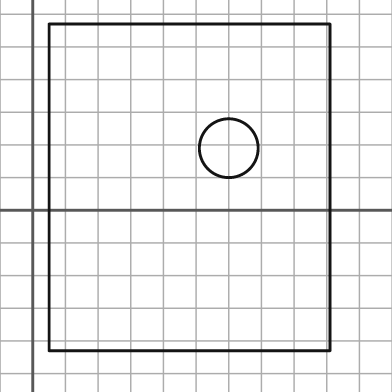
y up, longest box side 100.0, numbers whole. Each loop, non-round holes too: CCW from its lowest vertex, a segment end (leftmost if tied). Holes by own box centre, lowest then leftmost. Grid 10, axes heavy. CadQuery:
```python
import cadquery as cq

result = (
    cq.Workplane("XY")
    .moveTo(5.0, -43.0)
    .lineTo(91.0, -43.0)
    .lineTo(91.0, 57.0)
    .lineTo(5.0, 57.0)
    .close()
    .moveTo(60.0, 19.0)
    .circle(9.0)
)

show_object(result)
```